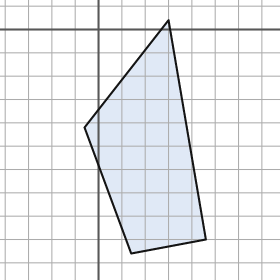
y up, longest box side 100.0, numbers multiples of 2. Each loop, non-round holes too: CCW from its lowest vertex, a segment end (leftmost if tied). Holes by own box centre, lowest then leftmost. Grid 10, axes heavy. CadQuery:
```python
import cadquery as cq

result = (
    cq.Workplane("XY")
    .moveTo(14.0, -96.0)
    .lineTo(46.0, -90.0)
    .lineTo(30.0, 4.0)
    .lineTo(-6.0, -42.0)
    .close()
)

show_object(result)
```